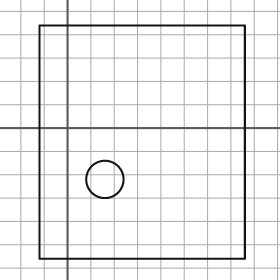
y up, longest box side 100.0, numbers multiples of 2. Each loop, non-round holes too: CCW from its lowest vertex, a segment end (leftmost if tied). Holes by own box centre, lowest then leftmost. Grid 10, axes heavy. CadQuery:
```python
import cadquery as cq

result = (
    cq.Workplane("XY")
    .moveTo(-12.0, -56.0)
    .lineTo(76.0, -56.0)
    .lineTo(76.0, 44.0)
    .lineTo(-12.0, 44.0)
    .close()
    .moveTo(16.0, -22.0)
    .circle(8.0)
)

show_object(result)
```